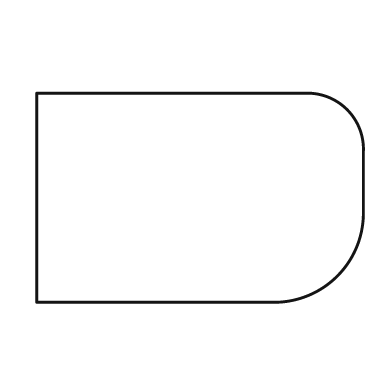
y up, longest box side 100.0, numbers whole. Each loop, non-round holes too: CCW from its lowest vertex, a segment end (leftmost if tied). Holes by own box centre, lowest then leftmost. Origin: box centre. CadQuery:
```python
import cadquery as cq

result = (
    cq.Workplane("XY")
    .moveTo(-50.0, -32.0)
    .lineTo(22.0, -32.0)
    .threePointArc((42.0, -24.0), (50.0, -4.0))
    .lineTo(50.0, 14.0)
    .threePointArc((45.0, 27.0), (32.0, 32.0))
    .lineTo(-50.0, 32.0)
    .close()
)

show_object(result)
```